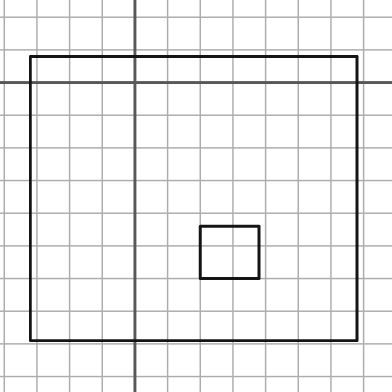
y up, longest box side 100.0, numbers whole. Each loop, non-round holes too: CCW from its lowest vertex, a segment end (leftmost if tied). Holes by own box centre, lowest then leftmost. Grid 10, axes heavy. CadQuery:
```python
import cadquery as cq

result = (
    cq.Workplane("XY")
    .moveTo(-32.0, -79.0)
    .lineTo(68.0, -79.0)
    .lineTo(68.0, 8.0)
    .lineTo(-32.0, 8.0)
    .close()
    .moveTo(20.0, -60.0)
    .lineTo(38.0, -60.0)
    .lineTo(38.0, -44.0)
    .lineTo(20.0, -44.0)
    .close()
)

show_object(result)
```